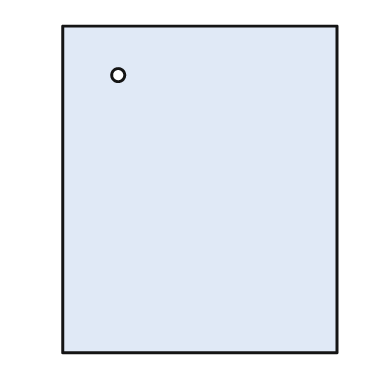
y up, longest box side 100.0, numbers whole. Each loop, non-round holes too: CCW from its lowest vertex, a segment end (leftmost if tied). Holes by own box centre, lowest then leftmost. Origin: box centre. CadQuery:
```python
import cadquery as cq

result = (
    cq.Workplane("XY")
    .moveTo(-42.0, -50.0)
    .lineTo(42.0, -50.0)
    .lineTo(42.0, 50.0)
    .lineTo(-42.0, 50.0)
    .close()
    .moveTo(-25.0, 35.0)
    .circle(2.0)
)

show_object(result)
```